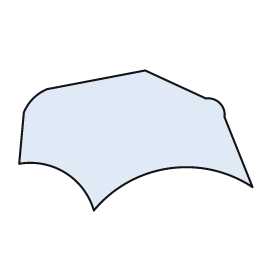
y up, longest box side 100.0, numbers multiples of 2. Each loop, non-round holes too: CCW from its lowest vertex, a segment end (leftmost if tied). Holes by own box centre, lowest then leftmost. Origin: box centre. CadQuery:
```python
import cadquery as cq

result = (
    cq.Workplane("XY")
    .moveTo(-18.0, -30.0)
    .threePointArc((14.0, -12.0), (50.0, -20.0))
    .lineTo(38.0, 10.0)
    .threePointArc((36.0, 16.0), (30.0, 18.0))
    .lineTo(4.0, 30.0)
    .lineTo(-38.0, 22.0)
    .threePointArc((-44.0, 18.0), (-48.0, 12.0))
    .lineTo(-50.0, -10.0)
    .threePointArc((-30.0, -14.0), (-18.0, -30.0))
    .close()
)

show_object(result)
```